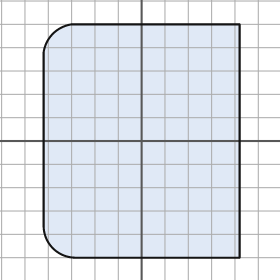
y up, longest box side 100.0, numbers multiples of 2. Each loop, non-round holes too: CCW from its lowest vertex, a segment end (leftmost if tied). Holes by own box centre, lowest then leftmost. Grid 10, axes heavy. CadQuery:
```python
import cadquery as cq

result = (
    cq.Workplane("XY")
    .moveTo(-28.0, -50.0)
    .lineTo(42.0, -50.0)
    .lineTo(42.0, 50.0)
    .lineTo(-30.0, 50.0)
    .threePointArc((-38.0, 46.0), (-42.0, 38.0))
    .lineTo(-42.0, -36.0)
    .threePointArc((-38.0, -46.0), (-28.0, -50.0))
    .close()
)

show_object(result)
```